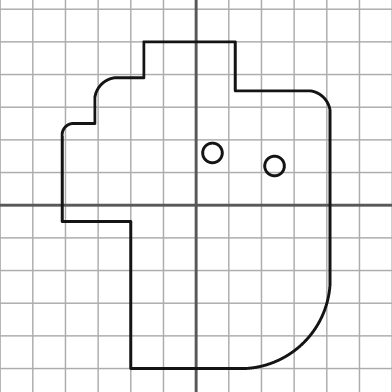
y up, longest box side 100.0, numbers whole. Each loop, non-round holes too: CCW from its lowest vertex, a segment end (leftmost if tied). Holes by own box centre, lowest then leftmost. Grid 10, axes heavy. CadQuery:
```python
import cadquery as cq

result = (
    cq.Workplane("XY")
    .moveTo(-20.0, -50.0)
    .lineTo(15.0, -50.0)
    .threePointArc((33.0, -42.0), (41.0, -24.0))
    .lineTo(41.0, 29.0)
    .threePointArc((39.0, 33.0), (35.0, 35.0))
    .lineTo(12.0, 35.0)
    .lineTo(12.0, 50.0)
    .lineTo(-16.0, 50.0)
    .lineTo(-16.0, 39.0)
    .lineTo(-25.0, 39.0)
    .threePointArc((-29.0, 37.0), (-31.0, 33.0))
    .lineTo(-31.0, 25.0)
    .lineTo(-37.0, 25.0)
    .threePointArc((-40.0, 24.0), (-41.0, 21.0))
    .lineTo(-41.0, -5.0)
    .lineTo(-20.0, -5.0)
    .close()
    .moveTo(24.0, 12.0)
    .circle(3.0)
    .moveTo(5.0, 16.0)
    .circle(3.0)
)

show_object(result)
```